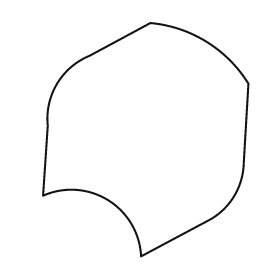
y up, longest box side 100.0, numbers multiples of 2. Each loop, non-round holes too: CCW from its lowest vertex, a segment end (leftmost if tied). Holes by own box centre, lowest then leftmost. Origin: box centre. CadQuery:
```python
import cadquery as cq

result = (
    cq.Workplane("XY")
    .moveTo(-2.0, -50.0)
    .lineTo(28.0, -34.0)
    .threePointArc((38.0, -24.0), (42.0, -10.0))
    .lineTo(44.0, 24.0)
    .threePointArc((26.0, 42.0), (2.0, 50.0))
    .lineTo(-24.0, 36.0)
    .threePointArc((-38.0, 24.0), (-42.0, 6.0))
    .lineTo(-44.0, -24.0)
    .threePointArc((-16.0, -26.0), (-2.0, -50.0))
    .close()
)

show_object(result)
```